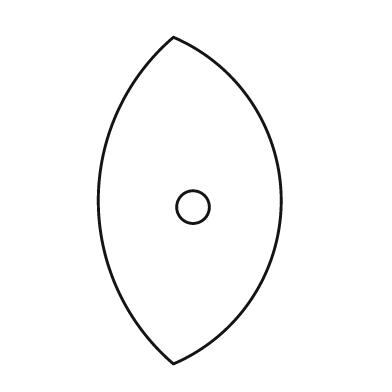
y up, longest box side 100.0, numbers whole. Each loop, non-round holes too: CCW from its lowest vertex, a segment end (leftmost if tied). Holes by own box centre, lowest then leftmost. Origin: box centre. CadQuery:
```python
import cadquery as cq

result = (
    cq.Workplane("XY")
    .moveTo(-5.0, -50.0)
    .threePointArc((28.0, 0.0), (-5.0, 50.0))
    .threePointArc((-28.0, 0.0), (-5.0, -50.0))
    .close()
    .moveTo(1.0, -2.0)
    .circle(5.0)
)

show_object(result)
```